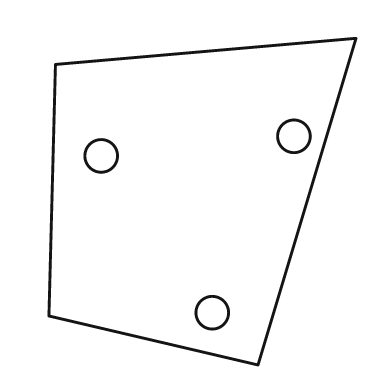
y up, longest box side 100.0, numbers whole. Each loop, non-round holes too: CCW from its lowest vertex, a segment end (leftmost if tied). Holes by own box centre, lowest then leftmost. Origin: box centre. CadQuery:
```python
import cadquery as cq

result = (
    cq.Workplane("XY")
    .moveTo(17.0, -50.0)
    .lineTo(47.0, 50.0)
    .lineTo(-45.0, 42.0)
    .lineTo(-47.0, -35.0)
    .close()
    .moveTo(3.0, -34.0)
    .circle(5.0)
    .moveTo(-31.0, 14.0)
    .circle(5.0)
    .moveTo(28.0, 20.0)
    .circle(5.0)
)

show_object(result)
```